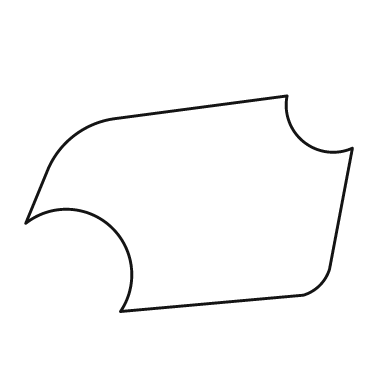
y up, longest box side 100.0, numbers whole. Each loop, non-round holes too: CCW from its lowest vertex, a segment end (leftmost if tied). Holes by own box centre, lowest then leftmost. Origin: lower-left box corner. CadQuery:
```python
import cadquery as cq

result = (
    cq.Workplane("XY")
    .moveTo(29.0, 0.0)
    .lineTo(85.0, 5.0)
    .threePointArc((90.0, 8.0), (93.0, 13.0))
    .lineTo(100.0, 50.0)
    .threePointArc((85.0, 52.0), (80.0, 66.0))
    .lineTo(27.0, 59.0)
    .threePointArc((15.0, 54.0), (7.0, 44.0))
    .lineTo(0.0, 27.0)
    .threePointArc((26.0, 26.0), (29.0, 0.0))
    .close()
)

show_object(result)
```